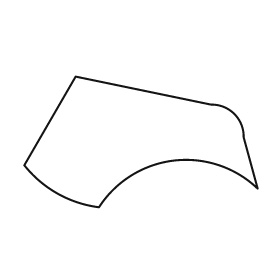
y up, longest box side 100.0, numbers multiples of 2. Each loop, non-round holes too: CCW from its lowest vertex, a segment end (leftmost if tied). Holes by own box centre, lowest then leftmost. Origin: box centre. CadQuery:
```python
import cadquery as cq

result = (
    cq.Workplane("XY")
    .moveTo(-18.0, -28.0)
    .threePointArc((14.0, -8.0), (50.0, -20.0))
    .lineTo(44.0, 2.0)
    .threePointArc((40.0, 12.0), (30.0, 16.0))
    .lineTo(-28.0, 28.0)
    .lineTo(-50.0, -10.0)
    .threePointArc((-36.0, -22.0), (-18.0, -28.0))
    .close()
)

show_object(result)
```